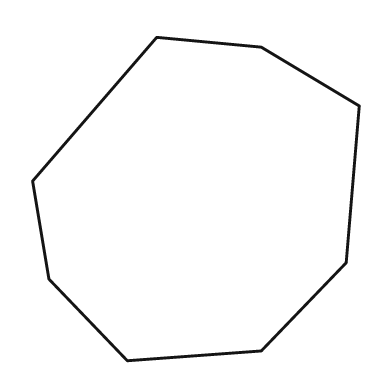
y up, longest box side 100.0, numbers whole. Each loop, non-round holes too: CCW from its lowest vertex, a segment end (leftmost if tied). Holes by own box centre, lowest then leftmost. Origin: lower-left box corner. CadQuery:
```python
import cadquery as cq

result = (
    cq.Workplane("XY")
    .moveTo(29.0, 0.0)
    .lineTo(70.0, 3.0)
    .lineTo(96.0, 30.0)
    .lineTo(100.0, 78.0)
    .lineTo(70.0, 96.0)
    .lineTo(38.0, 99.0)
    .lineTo(0.0, 55.0)
    .lineTo(5.0, 25.0)
    .close()
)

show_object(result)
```